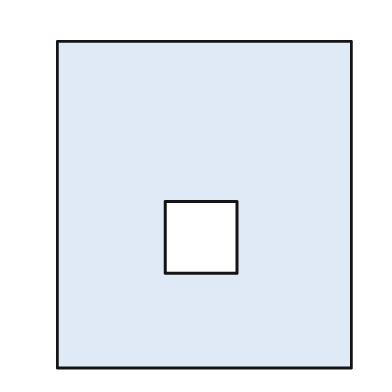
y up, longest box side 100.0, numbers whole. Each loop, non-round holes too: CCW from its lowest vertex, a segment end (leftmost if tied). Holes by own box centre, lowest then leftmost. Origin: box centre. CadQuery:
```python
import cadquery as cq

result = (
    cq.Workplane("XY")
    .moveTo(-45.0, -50.0)
    .lineTo(45.0, -50.0)
    .lineTo(45.0, 50.0)
    .lineTo(-45.0, 50.0)
    .close()
    .moveTo(-12.0, -21.0)
    .lineTo(10.0, -21.0)
    .lineTo(10.0, 1.0)
    .lineTo(-12.0, 1.0)
    .close()
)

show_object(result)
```